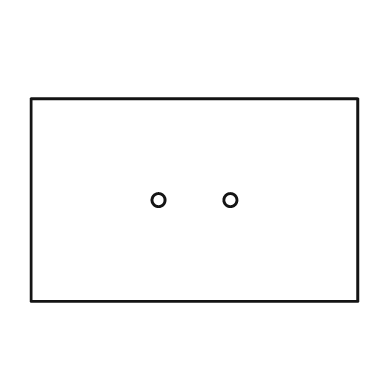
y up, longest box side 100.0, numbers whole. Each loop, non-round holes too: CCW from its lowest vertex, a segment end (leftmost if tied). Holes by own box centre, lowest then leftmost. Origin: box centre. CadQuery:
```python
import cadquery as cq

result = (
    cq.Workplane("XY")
    .moveTo(-50.0, -31.0)
    .lineTo(50.0, -31.0)
    .lineTo(50.0, 31.0)
    .lineTo(-50.0, 31.0)
    .close()
    .moveTo(-11.0, 0.0)
    .circle(2.0)
    .moveTo(11.0, 0.0)
    .circle(2.0)
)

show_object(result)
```